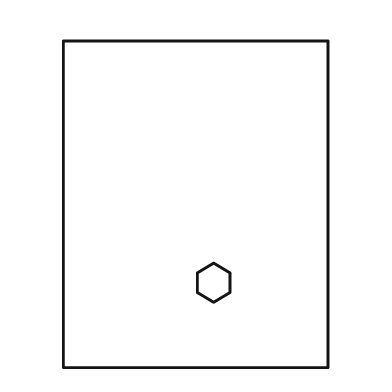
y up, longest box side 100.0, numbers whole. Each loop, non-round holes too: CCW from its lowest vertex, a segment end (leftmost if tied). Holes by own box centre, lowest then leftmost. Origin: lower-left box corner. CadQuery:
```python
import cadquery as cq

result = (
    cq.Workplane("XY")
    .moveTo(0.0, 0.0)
    .lineTo(81.0, 0.0)
    .lineTo(81.0, 100.0)
    .lineTo(0.0, 100.0)
    .close()
    .moveTo(46.0, 20.0)
    .lineTo(51.0, 23.0)
    .lineTo(51.0, 29.0)
    .lineTo(46.0, 32.0)
    .lineTo(41.0, 29.0)
    .lineTo(41.0, 23.0)
    .close()
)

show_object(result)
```